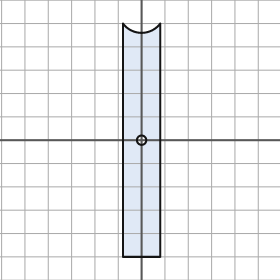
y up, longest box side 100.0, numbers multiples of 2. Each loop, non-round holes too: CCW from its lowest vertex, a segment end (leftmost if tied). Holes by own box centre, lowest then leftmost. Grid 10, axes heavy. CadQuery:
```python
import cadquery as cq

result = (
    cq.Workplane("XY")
    .moveTo(-8.0, -50.0)
    .lineTo(8.0, -50.0)
    .lineTo(8.0, 50.0)
    .threePointArc((0.0, 46.0), (-8.0, 50.0))
    .close()
    .moveTo(0.0, 0.0)
    .circle(2.0)
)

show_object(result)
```